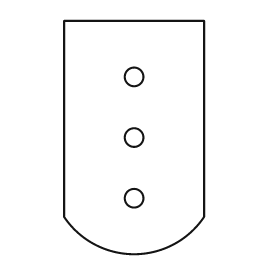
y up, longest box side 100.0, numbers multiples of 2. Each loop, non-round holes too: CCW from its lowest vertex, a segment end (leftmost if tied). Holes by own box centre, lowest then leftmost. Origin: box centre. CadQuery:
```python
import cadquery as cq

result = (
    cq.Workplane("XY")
    .moveTo(-30.0, -34.0)
    .threePointArc((0.0, -50.0), (30.0, -34.0))
    .lineTo(30.0, 50.0)
    .lineTo(-30.0, 50.0)
    .close()
    .moveTo(0.0, -26.0)
    .circle(4.0)
    .moveTo(0.0, 0.0)
    .circle(4.0)
    .moveTo(0.0, 26.0)
    .circle(4.0)
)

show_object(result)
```